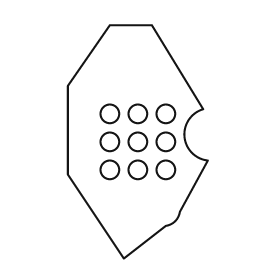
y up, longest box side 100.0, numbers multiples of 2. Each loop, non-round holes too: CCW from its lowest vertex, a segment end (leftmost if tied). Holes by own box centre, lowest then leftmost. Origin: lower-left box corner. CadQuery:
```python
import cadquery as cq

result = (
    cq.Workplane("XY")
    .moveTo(24.0, 0.0)
    .lineTo(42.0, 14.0)
    .threePointArc((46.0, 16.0), (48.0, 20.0))
    .lineTo(60.0, 42.0)
    .threePointArc((50.0, 52.0), (58.0, 64.0))
    .lineTo(36.0, 100.0)
    .lineTo(18.0, 100.0)
    .lineTo(0.0, 74.0)
    .lineTo(0.0, 36.0)
    .close()
    .moveTo(18.0, 38.0)
    .circle(4.0)
    .moveTo(30.0, 38.0)
    .circle(4.0)
    .moveTo(42.0, 38.0)
    .circle(4.0)
    .moveTo(18.0, 50.0)
    .circle(4.0)
    .moveTo(30.0, 50.0)
    .circle(4.0)
    .moveTo(42.0, 50.0)
    .circle(4.0)
    .moveTo(18.0, 62.0)
    .circle(4.0)
    .moveTo(30.0, 62.0)
    .circle(4.0)
    .moveTo(42.0, 62.0)
    .circle(4.0)
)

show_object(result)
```